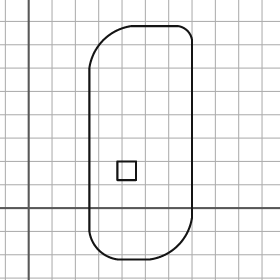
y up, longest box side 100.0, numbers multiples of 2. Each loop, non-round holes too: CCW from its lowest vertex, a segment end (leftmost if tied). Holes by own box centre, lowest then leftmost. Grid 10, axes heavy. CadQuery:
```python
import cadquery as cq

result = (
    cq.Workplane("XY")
    .moveTo(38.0, -22.0)
    .lineTo(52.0, -22.0)
    .threePointArc((64.0, -16.0), (70.0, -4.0))
    .lineTo(70.0, 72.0)
    .threePointArc((68.0, 76.0), (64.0, 78.0))
    .lineTo(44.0, 78.0)
    .threePointArc((32.0, 72.0), (26.0, 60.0))
    .lineTo(26.0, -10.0)
    .threePointArc((30.0, -18.0), (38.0, -22.0))
    .close()
    .moveTo(38.0, 12.0)
    .lineTo(46.0, 12.0)
    .lineTo(46.0, 20.0)
    .lineTo(38.0, 20.0)
    .close()
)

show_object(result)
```